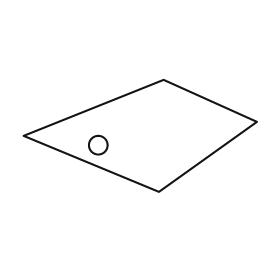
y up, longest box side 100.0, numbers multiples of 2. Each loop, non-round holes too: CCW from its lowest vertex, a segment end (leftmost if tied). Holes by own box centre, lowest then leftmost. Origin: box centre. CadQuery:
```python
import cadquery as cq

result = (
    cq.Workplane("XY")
    .moveTo(8.0, -24.0)
    .lineTo(50.0, 6.0)
    .lineTo(10.0, 24.0)
    .lineTo(-50.0, 0.0)
    .close()
    .moveTo(-18.0, -4.0)
    .circle(4.0)
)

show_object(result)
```